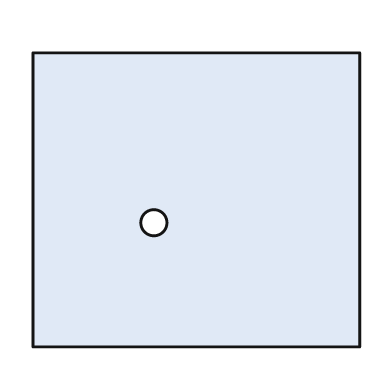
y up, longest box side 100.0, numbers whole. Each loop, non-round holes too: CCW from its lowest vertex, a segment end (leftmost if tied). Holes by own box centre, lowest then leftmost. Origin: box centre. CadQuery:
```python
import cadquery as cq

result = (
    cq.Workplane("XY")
    .moveTo(-50.0, -45.0)
    .lineTo(50.0, -45.0)
    .lineTo(50.0, 45.0)
    .lineTo(-50.0, 45.0)
    .close()
    .moveTo(-13.0, -7.0)
    .circle(4.0)
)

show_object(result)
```